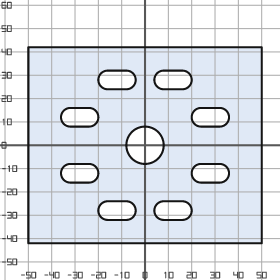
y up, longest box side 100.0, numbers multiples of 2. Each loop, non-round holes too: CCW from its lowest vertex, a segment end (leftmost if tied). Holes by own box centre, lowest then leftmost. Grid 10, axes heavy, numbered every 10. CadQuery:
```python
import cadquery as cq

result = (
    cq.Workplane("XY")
    .moveTo(-50.0, -42.0)
    .lineTo(50.0, -42.0)
    .lineTo(50.0, 42.0)
    .lineTo(-50.0, 42.0)
    .close()
    .moveTo(-16.0, -32.0)
    .lineTo(-8.0, -32.0)
    .threePointArc((-4.0, -28.0), (-8.0, -24.0))
    .lineTo(-16.0, -24.0)
    .threePointArc((-20.0, -28.0), (-16.0, -32.0))
    .close()
    .moveTo(8.0, -32.0)
    .lineTo(16.0, -32.0)
    .threePointArc((20.0, -28.0), (16.0, -24.0))
    .lineTo(8.0, -24.0)
    .threePointArc((4.0, -28.0), (8.0, -32.0))
    .close()
    .moveTo(-32.0, -16.0)
    .lineTo(-24.0, -16.0)
    .threePointArc((-20.0, -12.0), (-24.0, -8.0))
    .lineTo(-32.0, -8.0)
    .threePointArc((-36.0, -12.0), (-32.0, -16.0))
    .close()
    .moveTo(24.0, -16.0)
    .lineTo(32.0, -16.0)
    .threePointArc((36.0, -12.0), (32.0, -8.0))
    .lineTo(24.0, -8.0)
    .threePointArc((20.0, -12.0), (24.0, -16.0))
    .close()
    .moveTo(0.0, 0.0)
    .circle(8.0)
    .moveTo(-32.0, 8.0)
    .lineTo(-24.0, 8.0)
    .threePointArc((-20.0, 12.0), (-24.0, 16.0))
    .lineTo(-32.0, 16.0)
    .threePointArc((-36.0, 12.0), (-32.0, 8.0))
    .close()
    .moveTo(24.0, 8.0)
    .lineTo(32.0, 8.0)
    .threePointArc((36.0, 12.0), (32.0, 16.0))
    .lineTo(24.0, 16.0)
    .threePointArc((20.0, 12.0), (24.0, 8.0))
    .close()
    .moveTo(-16.0, 24.0)
    .lineTo(-8.0, 24.0)
    .threePointArc((-4.0, 28.0), (-8.0, 32.0))
    .lineTo(-16.0, 32.0)
    .threePointArc((-20.0, 28.0), (-16.0, 24.0))
    .close()
    .moveTo(8.0, 24.0)
    .lineTo(16.0, 24.0)
    .threePointArc((20.0, 28.0), (16.0, 32.0))
    .lineTo(8.0, 32.0)
    .threePointArc((4.0, 28.0), (8.0, 24.0))
    .close()
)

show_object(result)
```